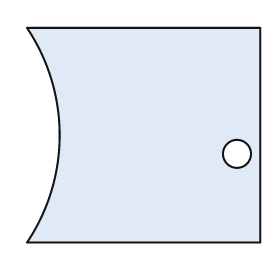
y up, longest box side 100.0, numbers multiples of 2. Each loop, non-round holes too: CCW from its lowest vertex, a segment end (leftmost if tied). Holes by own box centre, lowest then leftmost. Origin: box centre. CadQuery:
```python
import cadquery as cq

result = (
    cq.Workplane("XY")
    .moveTo(-50.0, -46.0)
    .lineTo(50.0, -46.0)
    .lineTo(50.0, 46.0)
    .lineTo(-50.0, 46.0)
    .threePointArc((-36.0, 0.0), (-50.0, -46.0))
    .close()
    .moveTo(40.0, -8.0)
    .circle(6.0)
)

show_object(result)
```